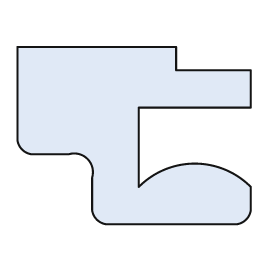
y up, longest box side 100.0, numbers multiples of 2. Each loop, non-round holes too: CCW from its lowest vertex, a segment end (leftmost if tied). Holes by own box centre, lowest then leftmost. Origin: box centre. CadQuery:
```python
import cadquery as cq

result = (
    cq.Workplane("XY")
    .moveTo(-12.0, -38.0)
    .lineTo(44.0, -38.0)
    .threePointArc((48.0, -36.0), (50.0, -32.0))
    .lineTo(50.0, -22.0)
    .threePointArc((26.0, -12.0), (2.0, -22.0))
    .lineTo(2.0, 12.0)
    .lineTo(50.0, 12.0)
    .lineTo(50.0, 28.0)
    .lineTo(18.0, 28.0)
    .lineTo(18.0, 38.0)
    .lineTo(-50.0, 38.0)
    .lineTo(-50.0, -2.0)
    .threePointArc((-48.0, -6.0), (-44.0, -8.0))
    .lineTo(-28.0, -8.0)
    .threePointArc((-20.0, -10.0), (-18.0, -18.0))
    .lineTo(-18.0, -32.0)
    .threePointArc((-16.0, -36.0), (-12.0, -38.0))
    .close()
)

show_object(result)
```